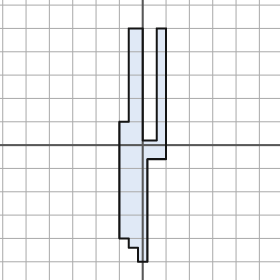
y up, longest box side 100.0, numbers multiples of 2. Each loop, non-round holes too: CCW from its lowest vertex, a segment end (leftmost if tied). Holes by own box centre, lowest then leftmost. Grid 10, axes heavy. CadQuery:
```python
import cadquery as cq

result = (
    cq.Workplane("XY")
    .moveTo(-2.0, -50.0)
    .lineTo(2.0, -50.0)
    .lineTo(2.0, -6.0)
    .lineTo(10.0, -6.0)
    .lineTo(10.0, 50.0)
    .lineTo(6.0, 50.0)
    .lineTo(6.0, 2.0)
    .lineTo(0.0, 2.0)
    .lineTo(0.0, 50.0)
    .lineTo(-6.0, 50.0)
    .lineTo(-6.0, 10.0)
    .lineTo(-10.0, 10.0)
    .lineTo(-10.0, -40.0)
    .lineTo(-6.0, -40.0)
    .lineTo(-6.0, -44.0)
    .lineTo(-2.0, -44.0)
    .close()
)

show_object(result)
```